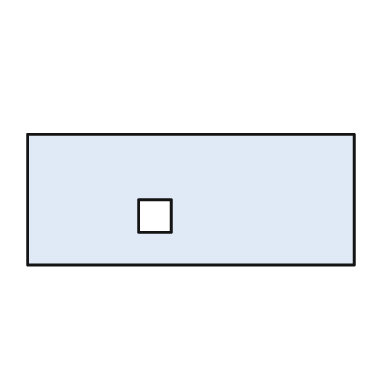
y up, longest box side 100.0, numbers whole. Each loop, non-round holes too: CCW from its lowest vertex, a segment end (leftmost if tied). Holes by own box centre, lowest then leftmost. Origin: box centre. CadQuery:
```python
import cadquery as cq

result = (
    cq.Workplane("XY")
    .moveTo(-50.0, -20.0)
    .lineTo(50.0, -20.0)
    .lineTo(50.0, 20.0)
    .lineTo(-50.0, 20.0)
    .close()
    .moveTo(-16.0, -10.0)
    .lineTo(-6.0, -10.0)
    .lineTo(-6.0, 0.0)
    .lineTo(-16.0, 0.0)
    .close()
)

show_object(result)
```